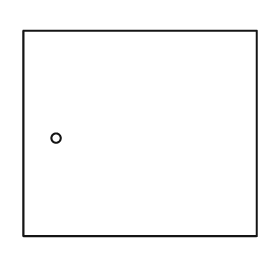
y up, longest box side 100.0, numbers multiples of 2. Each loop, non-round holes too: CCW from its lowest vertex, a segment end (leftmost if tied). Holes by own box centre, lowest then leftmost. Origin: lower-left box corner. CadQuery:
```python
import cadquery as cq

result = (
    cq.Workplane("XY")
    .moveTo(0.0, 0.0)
    .lineTo(100.0, 0.0)
    .lineTo(100.0, 88.0)
    .lineTo(0.0, 88.0)
    .close()
    .moveTo(14.0, 42.0)
    .circle(2.0)
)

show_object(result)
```